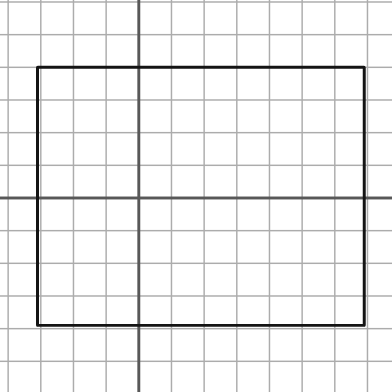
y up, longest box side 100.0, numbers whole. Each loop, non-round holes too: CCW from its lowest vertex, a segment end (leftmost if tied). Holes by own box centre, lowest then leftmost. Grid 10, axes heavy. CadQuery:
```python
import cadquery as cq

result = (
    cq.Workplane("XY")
    .moveTo(-31.0, -39.0)
    .lineTo(69.0, -39.0)
    .lineTo(69.0, 40.0)
    .lineTo(-31.0, 40.0)
    .close()
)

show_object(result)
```